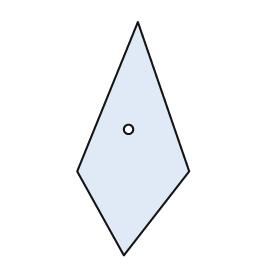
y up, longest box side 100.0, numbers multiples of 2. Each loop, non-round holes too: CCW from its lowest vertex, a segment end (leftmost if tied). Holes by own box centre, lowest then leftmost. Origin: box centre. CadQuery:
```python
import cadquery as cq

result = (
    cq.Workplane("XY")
    .moveTo(-4.0, -50.0)
    .lineTo(24.0, -14.0)
    .lineTo(2.0, 50.0)
    .lineTo(-24.0, -14.0)
    .close()
    .moveTo(-2.0, 4.0)
    .circle(2.0)
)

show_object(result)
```